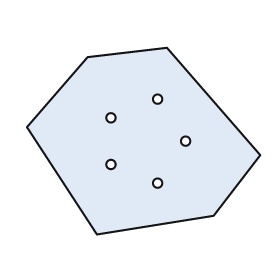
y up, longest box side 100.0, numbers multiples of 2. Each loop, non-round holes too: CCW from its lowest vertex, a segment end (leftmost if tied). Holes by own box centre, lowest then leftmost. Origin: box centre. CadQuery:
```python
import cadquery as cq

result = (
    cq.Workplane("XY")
    .moveTo(-20.0, -40.0)
    .lineTo(30.0, -32.0)
    .lineTo(50.0, -6.0)
    .lineTo(10.0, 40.0)
    .lineTo(-24.0, 36.0)
    .lineTo(-50.0, 6.0)
    .close()
    .moveTo(6.0, -18.0)
    .circle(2.0)
    .moveTo(-14.0, -10.0)
    .circle(2.0)
    .moveTo(18.0, 0.0)
    .circle(2.0)
    .moveTo(-14.0, 10.0)
    .circle(2.0)
    .moveTo(6.0, 18.0)
    .circle(2.0)
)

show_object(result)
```